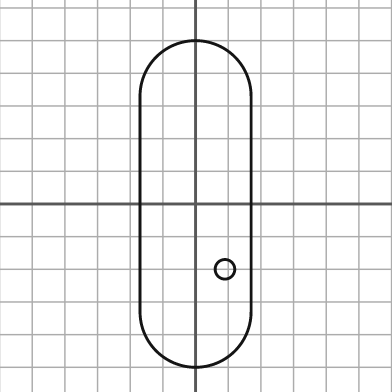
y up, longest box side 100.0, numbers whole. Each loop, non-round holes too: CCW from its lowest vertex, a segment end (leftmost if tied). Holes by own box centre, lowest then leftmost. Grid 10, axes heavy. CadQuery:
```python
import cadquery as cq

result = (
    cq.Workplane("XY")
    .moveTo(-17.0, -33.0)
    .threePointArc((0.0, -50.0), (17.0, -33.0))
    .lineTo(17.0, 33.0)
    .threePointArc((0.0, 50.0), (-17.0, 33.0))
    .close()
    .moveTo(9.0, -20.0)
    .circle(3.0)
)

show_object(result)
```